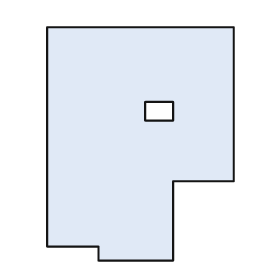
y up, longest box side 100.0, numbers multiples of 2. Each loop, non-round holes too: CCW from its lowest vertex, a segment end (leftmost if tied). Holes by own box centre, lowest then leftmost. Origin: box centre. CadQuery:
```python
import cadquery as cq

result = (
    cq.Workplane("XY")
    .moveTo(-18.0, -50.0)
    .lineTo(14.0, -50.0)
    .lineTo(14.0, -16.0)
    .lineTo(40.0, -16.0)
    .lineTo(40.0, 50.0)
    .lineTo(-40.0, 50.0)
    .lineTo(-40.0, -44.0)
    .lineTo(-18.0, -44.0)
    .close()
    .moveTo(2.0, 10.0)
    .lineTo(14.0, 10.0)
    .lineTo(14.0, 18.0)
    .lineTo(2.0, 18.0)
    .close()
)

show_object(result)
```